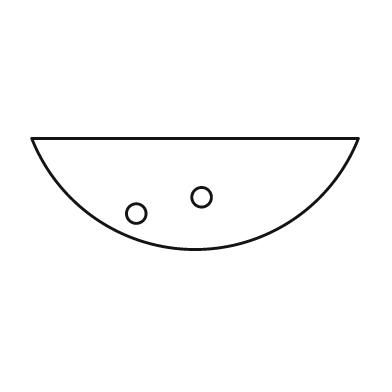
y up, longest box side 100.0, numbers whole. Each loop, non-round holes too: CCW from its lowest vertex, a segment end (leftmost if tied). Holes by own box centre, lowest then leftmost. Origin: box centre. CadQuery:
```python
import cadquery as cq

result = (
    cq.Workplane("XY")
    .moveTo(-50.0, 17.0)
    .threePointArc((0.0, -17.0), (50.0, 17.0))
    .close()
    .moveTo(-18.0, -6.0)
    .circle(3.0)
    .moveTo(2.0, -1.0)
    .circle(3.0)
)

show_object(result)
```